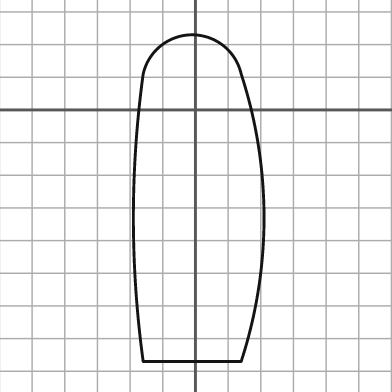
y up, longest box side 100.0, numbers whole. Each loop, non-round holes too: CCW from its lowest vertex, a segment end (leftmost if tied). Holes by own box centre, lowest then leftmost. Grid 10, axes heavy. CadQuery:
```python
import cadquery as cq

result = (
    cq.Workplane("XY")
    .moveTo(-16.0, -77.0)
    .lineTo(14.0, -77.0)
    .threePointArc((21.0, -33.0), (14.0, 11.0))
    .threePointArc((-1.0, 23.0), (-16.0, 11.0))
    .threePointArc((-19.0, -33.0), (-16.0, -77.0))
    .close()
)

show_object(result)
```